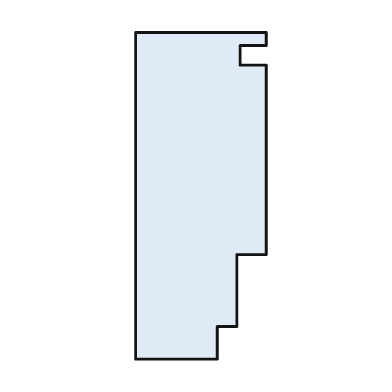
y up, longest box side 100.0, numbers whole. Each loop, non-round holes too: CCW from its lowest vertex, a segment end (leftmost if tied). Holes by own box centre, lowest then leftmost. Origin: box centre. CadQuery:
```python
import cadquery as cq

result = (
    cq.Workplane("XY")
    .moveTo(-20.0, -50.0)
    .lineTo(5.0, -50.0)
    .lineTo(5.0, -40.0)
    .lineTo(11.0, -40.0)
    .lineTo(11.0, -18.0)
    .lineTo(20.0, -18.0)
    .lineTo(20.0, 40.0)
    .lineTo(12.0, 40.0)
    .lineTo(12.0, 46.0)
    .lineTo(20.0, 46.0)
    .lineTo(20.0, 50.0)
    .lineTo(-20.0, 50.0)
    .close()
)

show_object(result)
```